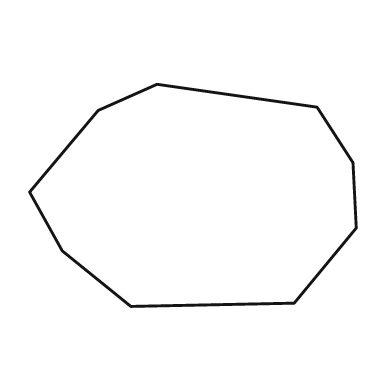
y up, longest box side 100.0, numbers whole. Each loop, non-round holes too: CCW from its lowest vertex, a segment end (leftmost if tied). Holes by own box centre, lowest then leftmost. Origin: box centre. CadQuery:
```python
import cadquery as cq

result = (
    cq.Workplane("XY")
    .moveTo(-19.0, -34.0)
    .lineTo(31.0, -33.0)
    .lineTo(50.0, -10.0)
    .lineTo(49.0, 10.0)
    .lineTo(38.0, 27.0)
    .lineTo(-11.0, 34.0)
    .lineTo(-29.0, 26.0)
    .lineTo(-50.0, 1.0)
    .lineTo(-40.0, -17.0)
    .close()
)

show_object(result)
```